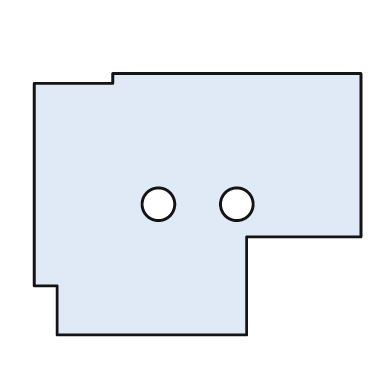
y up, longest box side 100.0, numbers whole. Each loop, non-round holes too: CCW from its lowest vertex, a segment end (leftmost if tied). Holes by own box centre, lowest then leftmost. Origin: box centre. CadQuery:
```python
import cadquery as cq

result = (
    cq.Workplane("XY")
    .moveTo(-43.0, -40.0)
    .lineTo(15.0, -40.0)
    .lineTo(15.0, -10.0)
    .lineTo(50.0, -10.0)
    .lineTo(50.0, 40.0)
    .lineTo(-26.0, 40.0)
    .lineTo(-26.0, 37.0)
    .lineTo(-50.0, 37.0)
    .lineTo(-50.0, -25.0)
    .lineTo(-43.0, -25.0)
    .close()
    .moveTo(-12.0, 0.0)
    .circle(5.0)
    .moveTo(12.0, 0.0)
    .circle(5.0)
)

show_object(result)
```